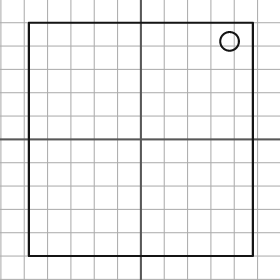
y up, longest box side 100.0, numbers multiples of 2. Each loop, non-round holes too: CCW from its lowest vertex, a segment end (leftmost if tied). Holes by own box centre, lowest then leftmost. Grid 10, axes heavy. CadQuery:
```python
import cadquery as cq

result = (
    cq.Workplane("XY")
    .moveTo(-48.0, -50.0)
    .lineTo(48.0, -50.0)
    .lineTo(48.0, 50.0)
    .lineTo(-48.0, 50.0)
    .close()
    .moveTo(38.0, 42.0)
    .circle(4.0)
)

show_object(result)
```